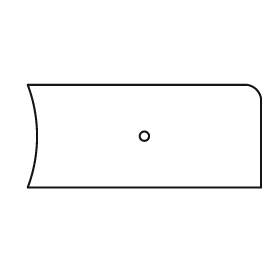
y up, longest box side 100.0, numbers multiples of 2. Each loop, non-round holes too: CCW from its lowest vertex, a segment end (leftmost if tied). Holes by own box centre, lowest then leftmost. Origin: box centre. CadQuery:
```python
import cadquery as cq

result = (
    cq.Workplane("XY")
    .moveTo(-50.0, -22.0)
    .lineTo(50.0, -22.0)
    .lineTo(50.0, 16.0)
    .threePointArc((48.0, 20.0), (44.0, 22.0))
    .lineTo(-50.0, 22.0)
    .threePointArc((-46.0, 0.0), (-50.0, -22.0))
    .close()
    .moveTo(0.0, 0.0)
    .circle(2.0)
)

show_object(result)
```